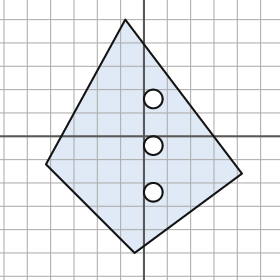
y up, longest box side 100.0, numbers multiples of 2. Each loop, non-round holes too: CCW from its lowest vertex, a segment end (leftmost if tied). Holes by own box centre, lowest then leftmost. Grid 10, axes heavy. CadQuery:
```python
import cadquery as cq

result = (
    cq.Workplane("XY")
    .moveTo(-4.0, -50.0)
    .lineTo(42.0, -16.0)
    .lineTo(-8.0, 50.0)
    .lineTo(-42.0, -12.0)
    .close()
    .moveTo(4.0, -24.0)
    .circle(4.0)
    .moveTo(4.0, -4.0)
    .circle(4.0)
    .moveTo(4.0, 16.0)
    .circle(4.0)
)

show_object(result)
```